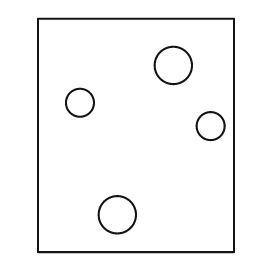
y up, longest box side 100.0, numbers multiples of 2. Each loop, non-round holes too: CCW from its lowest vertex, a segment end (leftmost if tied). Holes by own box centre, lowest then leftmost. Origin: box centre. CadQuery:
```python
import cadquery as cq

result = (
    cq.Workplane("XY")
    .moveTo(-42.0, -50.0)
    .lineTo(42.0, -50.0)
    .lineTo(42.0, 50.0)
    .lineTo(-42.0, 50.0)
    .close()
    .moveTo(-8.0, -34.0)
    .circle(8.0)
    .moveTo(32.0, 4.0)
    .circle(6.0)
    .moveTo(-24.0, 14.0)
    .circle(6.0)
    .moveTo(16.0, 30.0)
    .circle(8.0)
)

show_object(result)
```